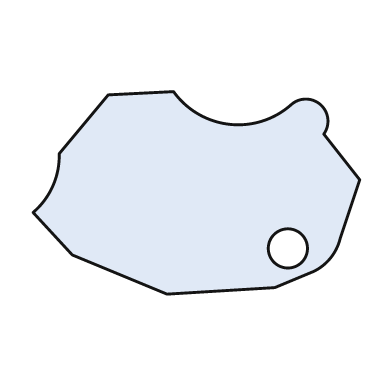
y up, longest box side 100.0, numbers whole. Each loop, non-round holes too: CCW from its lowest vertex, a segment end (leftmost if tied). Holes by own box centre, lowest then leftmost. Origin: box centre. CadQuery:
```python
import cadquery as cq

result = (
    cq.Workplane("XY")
    .moveTo(-9.0, -31.0)
    .lineTo(24.0, -29.0)
    .lineTo(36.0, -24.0)
    .threePointArc((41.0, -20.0), (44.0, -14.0))
    .lineTo(50.0, 4.0)
    .lineTo(39.0, 18.0)
    .threePointArc((38.0, 27.0), (29.0, 27.0))
    .threePointArc((10.0, 21.0), (-7.0, 31.0))
    .lineTo(-27.0, 30.0)
    .lineTo(-42.0, 12.0)
    .threePointArc((-44.0, 2.0), (-50.0, -6.0))
    .lineTo(-38.0, -19.0)
    .close()
    .moveTo(28.0, -17.0)
    .circle(6.0)
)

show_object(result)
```